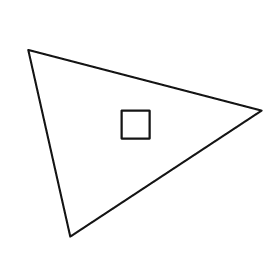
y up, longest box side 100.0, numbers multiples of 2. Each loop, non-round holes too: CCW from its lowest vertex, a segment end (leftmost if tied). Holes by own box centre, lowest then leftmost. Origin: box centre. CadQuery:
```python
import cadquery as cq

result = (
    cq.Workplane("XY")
    .moveTo(-32.0, -40.0)
    .lineTo(50.0, 14.0)
    .lineTo(-50.0, 40.0)
    .close()
    .moveTo(-10.0, 2.0)
    .lineTo(2.0, 2.0)
    .lineTo(2.0, 14.0)
    .lineTo(-10.0, 14.0)
    .close()
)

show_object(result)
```